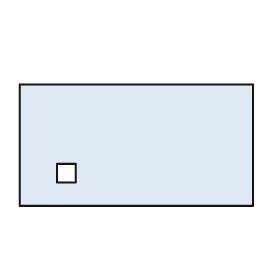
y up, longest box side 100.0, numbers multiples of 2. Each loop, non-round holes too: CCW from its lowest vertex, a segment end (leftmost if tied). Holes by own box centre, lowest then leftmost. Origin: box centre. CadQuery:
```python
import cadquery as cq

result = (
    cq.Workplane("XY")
    .moveTo(-50.0, -26.0)
    .lineTo(50.0, -26.0)
    .lineTo(50.0, 26.0)
    .lineTo(-50.0, 26.0)
    .close()
    .moveTo(-34.0, -16.0)
    .lineTo(-26.0, -16.0)
    .lineTo(-26.0, -8.0)
    .lineTo(-34.0, -8.0)
    .close()
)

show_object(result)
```